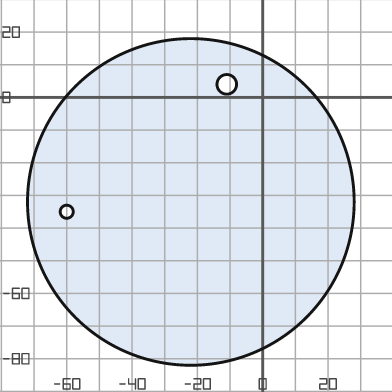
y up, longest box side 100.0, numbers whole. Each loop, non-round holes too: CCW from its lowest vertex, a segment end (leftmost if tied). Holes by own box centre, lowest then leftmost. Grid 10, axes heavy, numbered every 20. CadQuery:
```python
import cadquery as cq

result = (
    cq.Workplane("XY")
    .moveTo(-22.0, -32.0)
    .circle(50.0)
    .moveTo(-60.0, -35.0)
    .circle(2.0)
    .moveTo(-11.0, 4.0)
    .circle(3.0)
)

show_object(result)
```